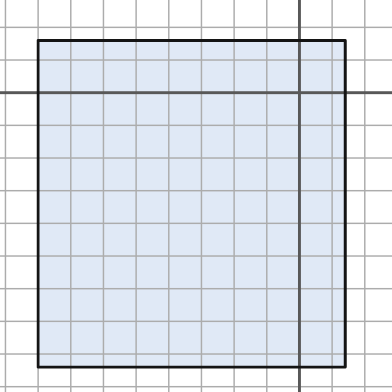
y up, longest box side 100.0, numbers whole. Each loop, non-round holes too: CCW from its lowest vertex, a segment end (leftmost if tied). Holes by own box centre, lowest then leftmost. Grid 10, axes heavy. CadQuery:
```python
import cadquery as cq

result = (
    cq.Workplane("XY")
    .moveTo(-80.0, -84.0)
    .lineTo(14.0, -84.0)
    .lineTo(14.0, 16.0)
    .lineTo(-80.0, 16.0)
    .close()
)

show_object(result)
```